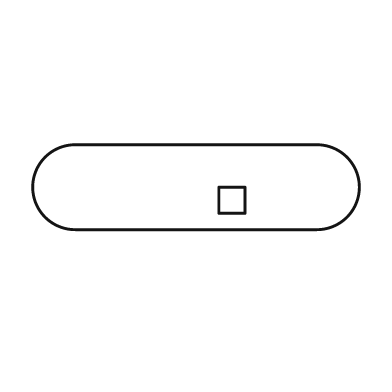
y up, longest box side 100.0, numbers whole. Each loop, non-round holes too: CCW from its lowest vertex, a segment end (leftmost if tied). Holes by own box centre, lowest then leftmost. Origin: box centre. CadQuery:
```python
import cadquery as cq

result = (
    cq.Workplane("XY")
    .moveTo(-37.0, -13.0)
    .lineTo(37.0, -13.0)
    .threePointArc((50.0, 0.0), (37.0, 13.0))
    .lineTo(-37.0, 13.0)
    .threePointArc((-50.0, 0.0), (-37.0, -13.0))
    .close()
    .moveTo(7.0, -8.0)
    .lineTo(15.0, -8.0)
    .lineTo(15.0, 0.0)
    .lineTo(7.0, 0.0)
    .close()
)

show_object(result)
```